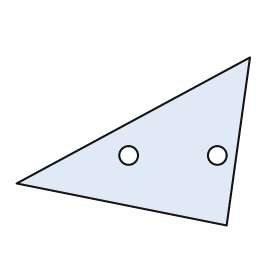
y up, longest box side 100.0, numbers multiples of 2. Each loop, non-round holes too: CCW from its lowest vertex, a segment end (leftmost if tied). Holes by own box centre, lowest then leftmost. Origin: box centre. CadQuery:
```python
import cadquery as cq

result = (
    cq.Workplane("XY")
    .moveTo(40.0, -36.0)
    .lineTo(50.0, 36.0)
    .lineTo(-50.0, -18.0)
    .close()
    .moveTo(-2.0, -6.0)
    .circle(4.0)
    .moveTo(36.0, -6.0)
    .circle(4.0)
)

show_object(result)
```